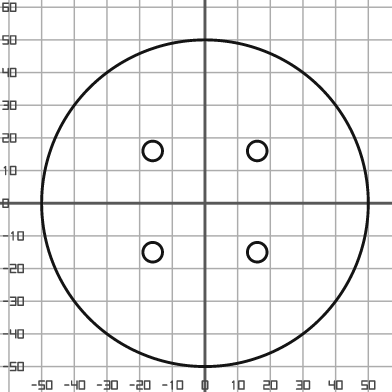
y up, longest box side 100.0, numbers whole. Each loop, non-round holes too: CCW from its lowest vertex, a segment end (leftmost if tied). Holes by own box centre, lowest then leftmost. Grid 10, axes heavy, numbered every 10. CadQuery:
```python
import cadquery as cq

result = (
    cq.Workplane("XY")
    .moveTo(0.0, 0.0)
    .circle(50.0)
    .moveTo(-16.0, -15.0)
    .circle(3.0)
    .moveTo(16.0, -15.0)
    .circle(3.0)
    .moveTo(-16.0, 16.0)
    .circle(3.0)
    .moveTo(16.0, 16.0)
    .circle(3.0)
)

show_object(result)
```